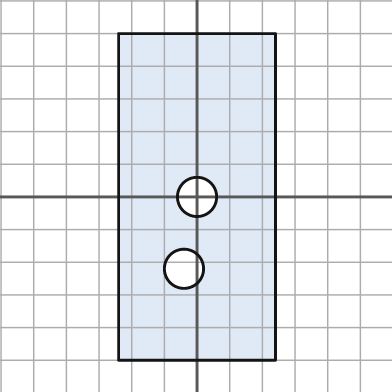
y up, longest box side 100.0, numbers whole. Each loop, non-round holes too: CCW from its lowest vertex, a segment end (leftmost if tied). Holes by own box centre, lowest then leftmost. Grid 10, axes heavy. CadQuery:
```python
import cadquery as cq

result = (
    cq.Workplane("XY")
    .moveTo(-24.0, -50.0)
    .lineTo(24.0, -50.0)
    .lineTo(24.0, 50.0)
    .lineTo(-24.0, 50.0)
    .close()
    .moveTo(-4.0, -22.0)
    .circle(6.0)
    .moveTo(0.0, 0.0)
    .circle(6.0)
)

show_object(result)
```